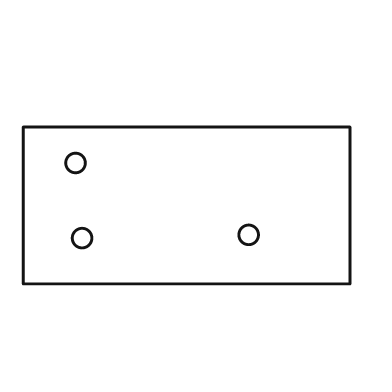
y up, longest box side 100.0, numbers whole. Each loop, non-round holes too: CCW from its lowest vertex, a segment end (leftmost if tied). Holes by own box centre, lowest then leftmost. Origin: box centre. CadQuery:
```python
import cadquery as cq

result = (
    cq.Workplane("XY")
    .moveTo(-50.0, -24.0)
    .lineTo(50.0, -24.0)
    .lineTo(50.0, 24.0)
    .lineTo(-50.0, 24.0)
    .close()
    .moveTo(-32.0, -10.0)
    .circle(3.0)
    .moveTo(19.0, -9.0)
    .circle(3.0)
    .moveTo(-34.0, 13.0)
    .circle(3.0)
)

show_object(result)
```